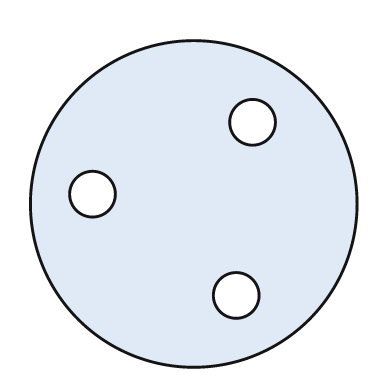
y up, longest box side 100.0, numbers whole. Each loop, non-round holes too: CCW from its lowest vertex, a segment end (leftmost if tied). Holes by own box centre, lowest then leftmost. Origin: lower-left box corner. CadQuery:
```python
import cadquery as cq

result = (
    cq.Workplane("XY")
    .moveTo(50.0, 50.0)
    .circle(50.0)
    .moveTo(63.0, 22.0)
    .circle(7.0)
    .moveTo(19.0, 53.0)
    .circle(7.0)
    .moveTo(68.0, 75.0)
    .circle(7.0)
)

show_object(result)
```